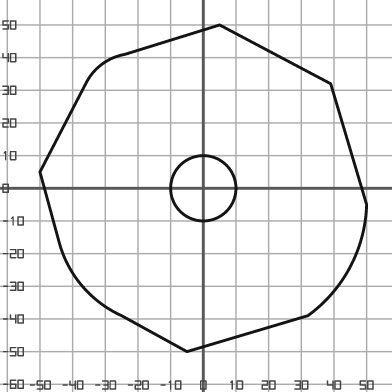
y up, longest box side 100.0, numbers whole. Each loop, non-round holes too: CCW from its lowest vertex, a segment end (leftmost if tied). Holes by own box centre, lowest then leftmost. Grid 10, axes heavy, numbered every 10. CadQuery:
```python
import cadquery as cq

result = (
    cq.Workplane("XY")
    .moveTo(-5.0, -50.0)
    .lineTo(32.0, -39.0)
    .threePointArc((45.0, -24.0), (50.0, -5.0))
    .lineTo(39.0, 32.0)
    .lineTo(5.0, 50.0)
    .lineTo(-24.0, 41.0)
    .threePointArc((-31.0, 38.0), (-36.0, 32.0))
    .lineTo(-50.0, 5.0)
    .lineTo(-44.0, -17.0)
    .threePointArc((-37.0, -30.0), (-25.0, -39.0))
    .close()
    .moveTo(0.0, 0.0)
    .circle(10.0)
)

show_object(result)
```